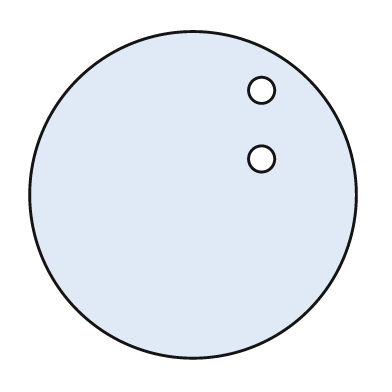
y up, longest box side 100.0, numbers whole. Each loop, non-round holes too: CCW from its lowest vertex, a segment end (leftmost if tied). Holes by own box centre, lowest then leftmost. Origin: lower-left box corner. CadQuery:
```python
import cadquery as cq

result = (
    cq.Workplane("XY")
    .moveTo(50.0, 50.0)
    .circle(50.0)
    .moveTo(71.0, 61.0)
    .circle(4.0)
    .moveTo(71.0, 82.0)
    .circle(4.0)
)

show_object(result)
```